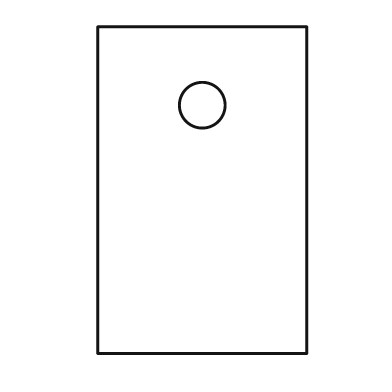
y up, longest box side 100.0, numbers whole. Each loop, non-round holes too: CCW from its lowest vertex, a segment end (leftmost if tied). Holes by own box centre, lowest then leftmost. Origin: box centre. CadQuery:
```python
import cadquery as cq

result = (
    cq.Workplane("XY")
    .moveTo(-32.0, -50.0)
    .lineTo(32.0, -50.0)
    .lineTo(32.0, 50.0)
    .lineTo(-32.0, 50.0)
    .close()
    .moveTo(0.0, 26.0)
    .circle(7.0)
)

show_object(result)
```